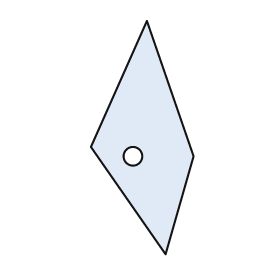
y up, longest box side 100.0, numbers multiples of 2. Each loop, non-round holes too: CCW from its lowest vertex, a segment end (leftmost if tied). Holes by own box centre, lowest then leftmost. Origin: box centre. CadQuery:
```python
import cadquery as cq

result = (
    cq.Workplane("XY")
    .moveTo(10.0, -50.0)
    .lineTo(22.0, -8.0)
    .lineTo(2.0, 50.0)
    .lineTo(-22.0, -4.0)
    .close()
    .moveTo(-4.0, -8.0)
    .circle(4.0)
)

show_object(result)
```